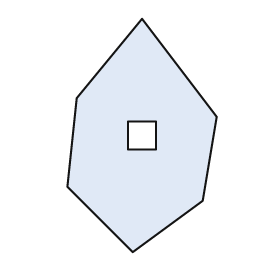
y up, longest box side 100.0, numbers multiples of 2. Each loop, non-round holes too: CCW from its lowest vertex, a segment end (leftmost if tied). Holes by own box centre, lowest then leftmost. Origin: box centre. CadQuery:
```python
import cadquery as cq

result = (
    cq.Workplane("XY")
    .moveTo(-4.0, -50.0)
    .lineTo(26.0, -28.0)
    .lineTo(32.0, 8.0)
    .lineTo(0.0, 50.0)
    .lineTo(-28.0, 16.0)
    .lineTo(-32.0, -22.0)
    .close()
    .moveTo(-6.0, -6.0)
    .lineTo(6.0, -6.0)
    .lineTo(6.0, 6.0)
    .lineTo(-6.0, 6.0)
    .close()
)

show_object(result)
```